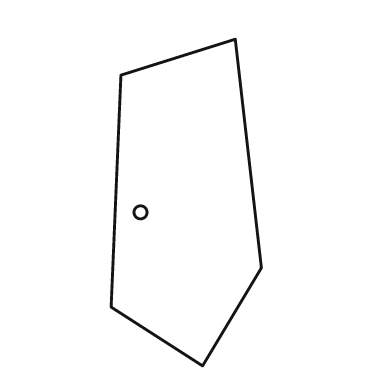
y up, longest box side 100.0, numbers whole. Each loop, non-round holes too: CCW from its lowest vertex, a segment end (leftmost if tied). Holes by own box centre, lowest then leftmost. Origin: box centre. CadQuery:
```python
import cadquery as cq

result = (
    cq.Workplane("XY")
    .moveTo(5.0, -50.0)
    .lineTo(23.0, -20.0)
    .lineTo(15.0, 50.0)
    .lineTo(-20.0, 39.0)
    .lineTo(-23.0, -32.0)
    .close()
    .moveTo(-14.0, -3.0)
    .circle(2.0)
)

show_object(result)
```